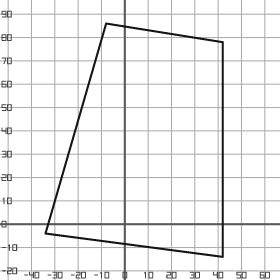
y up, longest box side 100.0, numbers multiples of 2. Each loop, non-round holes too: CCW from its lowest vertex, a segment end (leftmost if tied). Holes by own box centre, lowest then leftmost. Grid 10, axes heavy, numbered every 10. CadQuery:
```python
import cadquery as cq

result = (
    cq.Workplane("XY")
    .moveTo(42.0, -14.0)
    .lineTo(42.0, 78.0)
    .lineTo(-8.0, 86.0)
    .lineTo(-34.0, -4.0)
    .close()
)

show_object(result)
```